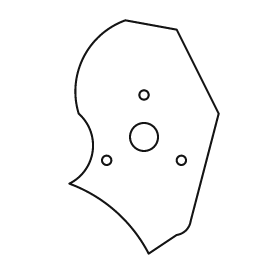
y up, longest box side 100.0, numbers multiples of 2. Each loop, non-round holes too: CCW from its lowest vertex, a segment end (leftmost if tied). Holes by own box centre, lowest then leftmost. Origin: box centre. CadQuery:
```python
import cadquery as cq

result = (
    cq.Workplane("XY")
    .moveTo(2.0, -50.0)
    .lineTo(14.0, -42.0)
    .threePointArc((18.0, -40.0), (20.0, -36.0))
    .lineTo(32.0, 10.0)
    .lineTo(14.0, 46.0)
    .lineTo(-8.0, 50.0)
    .threePointArc((-26.0, 34.0), (-28.0, 10.0))
    .threePointArc((-22.0, -6.0), (-32.0, -20.0))
    .threePointArc((-12.0, -32.0), (2.0, -50.0))
    .close()
    .moveTo(-16.0, -10.0)
    .circle(2.0)
    .moveTo(16.0, -10.0)
    .circle(2.0)
    .moveTo(0.0, 0.0)
    .circle(6.0)
    .moveTo(0.0, 18.0)
    .circle(2.0)
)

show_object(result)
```